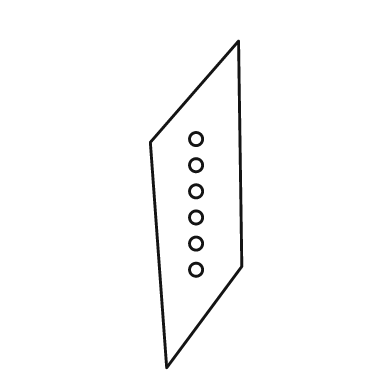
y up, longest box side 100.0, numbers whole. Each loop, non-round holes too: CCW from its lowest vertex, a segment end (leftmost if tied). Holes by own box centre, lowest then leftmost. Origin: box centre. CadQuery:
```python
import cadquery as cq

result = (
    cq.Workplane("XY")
    .moveTo(-9.0, -50.0)
    .lineTo(14.0, -19.0)
    .lineTo(13.0, 50.0)
    .lineTo(-14.0, 19.0)
    .close()
    .moveTo(0.0, -20.0)
    .circle(2.0)
    .moveTo(0.0, -12.0)
    .circle(2.0)
    .moveTo(0.0, -4.0)
    .circle(2.0)
    .moveTo(0.0, 4.0)
    .circle(2.0)
    .moveTo(0.0, 12.0)
    .circle(2.0)
    .moveTo(0.0, 20.0)
    .circle(2.0)
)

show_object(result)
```